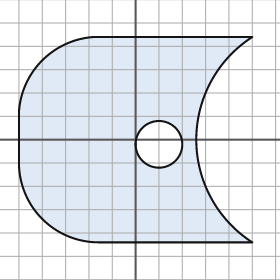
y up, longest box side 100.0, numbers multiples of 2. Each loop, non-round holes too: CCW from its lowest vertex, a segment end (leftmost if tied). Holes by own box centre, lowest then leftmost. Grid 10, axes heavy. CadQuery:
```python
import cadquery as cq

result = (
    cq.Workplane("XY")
    .moveTo(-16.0, -44.0)
    .lineTo(50.0, -44.0)
    .threePointArc((26.0, 0.0), (50.0, 44.0))
    .lineTo(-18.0, 44.0)
    .threePointArc((-40.0, 34.0), (-50.0, 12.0))
    .lineTo(-50.0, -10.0)
    .threePointArc((-40.0, -34.0), (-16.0, -44.0))
    .close()
    .moveTo(10.0, -2.0)
    .circle(10.0)
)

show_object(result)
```